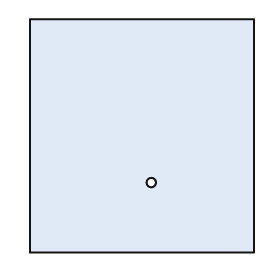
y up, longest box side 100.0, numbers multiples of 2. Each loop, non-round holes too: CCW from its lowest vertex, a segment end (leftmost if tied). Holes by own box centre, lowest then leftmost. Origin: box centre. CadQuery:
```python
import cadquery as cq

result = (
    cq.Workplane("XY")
    .moveTo(-48.0, -50.0)
    .lineTo(48.0, -50.0)
    .lineTo(48.0, 50.0)
    .lineTo(-48.0, 50.0)
    .close()
    .moveTo(4.0, -20.0)
    .circle(2.0)
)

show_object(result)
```